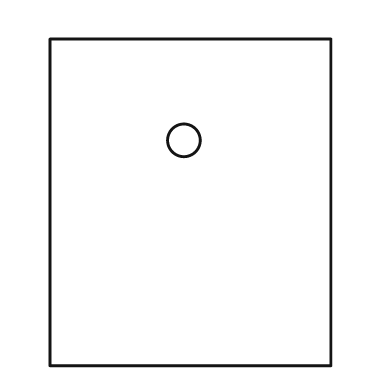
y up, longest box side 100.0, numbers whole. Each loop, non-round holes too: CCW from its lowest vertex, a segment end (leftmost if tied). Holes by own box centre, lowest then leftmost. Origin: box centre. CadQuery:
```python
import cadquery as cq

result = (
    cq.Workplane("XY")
    .moveTo(-43.0, -50.0)
    .lineTo(43.0, -50.0)
    .lineTo(43.0, 50.0)
    .lineTo(-43.0, 50.0)
    .close()
    .moveTo(-2.0, 19.0)
    .circle(5.0)
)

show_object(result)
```